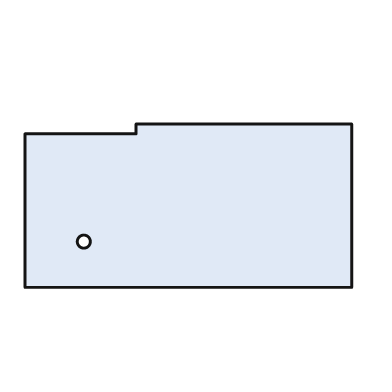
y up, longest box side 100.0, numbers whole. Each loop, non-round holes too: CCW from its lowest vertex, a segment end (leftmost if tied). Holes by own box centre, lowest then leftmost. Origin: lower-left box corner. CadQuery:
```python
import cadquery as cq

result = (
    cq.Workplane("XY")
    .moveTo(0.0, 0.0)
    .lineTo(100.0, 0.0)
    .lineTo(100.0, 50.0)
    .lineTo(34.0, 50.0)
    .lineTo(34.0, 47.0)
    .lineTo(0.0, 47.0)
    .close()
    .moveTo(18.0, 14.0)
    .circle(2.0)
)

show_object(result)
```